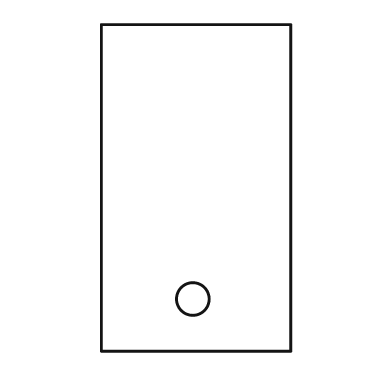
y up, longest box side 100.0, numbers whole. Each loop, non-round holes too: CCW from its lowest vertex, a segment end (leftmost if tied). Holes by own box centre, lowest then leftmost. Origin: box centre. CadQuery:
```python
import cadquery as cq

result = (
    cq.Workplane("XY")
    .moveTo(-29.0, -50.0)
    .lineTo(29.0, -50.0)
    .lineTo(29.0, 50.0)
    .lineTo(-29.0, 50.0)
    .close()
    .moveTo(-1.0, -34.0)
    .circle(5.0)
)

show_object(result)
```